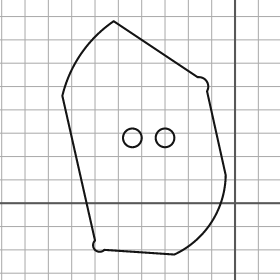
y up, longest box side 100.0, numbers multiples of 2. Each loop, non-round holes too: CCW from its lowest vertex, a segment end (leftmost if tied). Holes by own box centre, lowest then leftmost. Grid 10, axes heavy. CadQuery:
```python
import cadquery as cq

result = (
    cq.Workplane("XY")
    .moveTo(-26.0, -22.0)
    .threePointArc((-10.0, -8.0), (-4.0, 12.0))
    .lineTo(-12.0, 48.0)
    .threePointArc((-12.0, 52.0), (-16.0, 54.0))
    .lineTo(-52.0, 78.0)
    .threePointArc((-66.0, 64.0), (-74.0, 46.0))
    .lineTo(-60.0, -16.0)
    .threePointArc((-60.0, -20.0), (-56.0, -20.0))
    .close()
    .moveTo(-44.0, 28.0)
    .circle(4.0)
    .moveTo(-30.0, 28.0)
    .circle(4.0)
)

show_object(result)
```